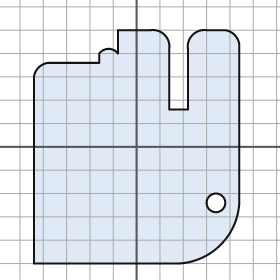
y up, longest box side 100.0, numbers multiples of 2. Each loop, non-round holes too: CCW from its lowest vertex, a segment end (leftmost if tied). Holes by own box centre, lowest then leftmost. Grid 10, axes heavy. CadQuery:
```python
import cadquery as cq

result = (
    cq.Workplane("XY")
    .moveTo(-44.0, -50.0)
    .lineTo(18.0, -50.0)
    .threePointArc((36.0, -42.0), (44.0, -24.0))
    .lineTo(44.0, 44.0)
    .threePointArc((42.0, 48.0), (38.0, 50.0))
    .lineTo(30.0, 50.0)
    .threePointArc((24.0, 48.0), (22.0, 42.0))
    .lineTo(22.0, 16.0)
    .lineTo(14.0, 16.0)
    .lineTo(14.0, 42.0)
    .threePointArc((12.0, 48.0), (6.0, 50.0))
    .lineTo(-8.0, 50.0)
    .lineTo(-8.0, 40.0)
    .threePointArc((-12.0, 42.0), (-16.0, 40.0))
    .lineTo(-16.0, 36.0)
    .lineTo(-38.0, 36.0)
    .threePointArc((-42.0, 34.0), (-44.0, 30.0))
    .close()
    .moveTo(34.0, -24.0)
    .circle(4.0)
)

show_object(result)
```